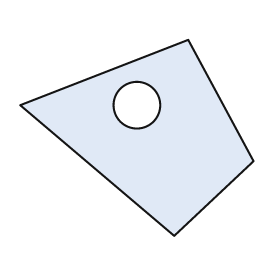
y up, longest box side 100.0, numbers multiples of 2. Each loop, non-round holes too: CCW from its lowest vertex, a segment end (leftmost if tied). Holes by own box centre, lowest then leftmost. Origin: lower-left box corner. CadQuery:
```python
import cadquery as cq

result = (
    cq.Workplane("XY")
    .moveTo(66.0, 0.0)
    .lineTo(100.0, 32.0)
    .lineTo(72.0, 84.0)
    .lineTo(0.0, 56.0)
    .close()
    .moveTo(50.0, 56.0)
    .circle(10.0)
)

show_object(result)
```